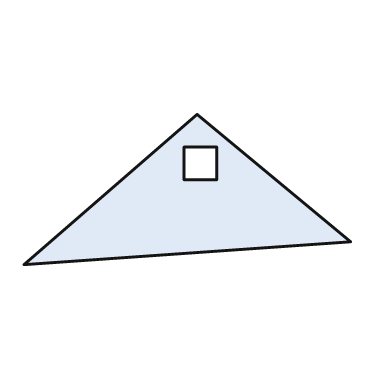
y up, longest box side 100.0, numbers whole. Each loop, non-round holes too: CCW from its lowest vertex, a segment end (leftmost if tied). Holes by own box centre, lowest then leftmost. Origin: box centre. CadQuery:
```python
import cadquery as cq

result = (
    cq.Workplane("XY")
    .moveTo(-50.0, -23.0)
    .lineTo(50.0, -16.0)
    .lineTo(3.0, 23.0)
    .close()
    .moveTo(-1.0, 3.0)
    .lineTo(9.0, 3.0)
    .lineTo(9.0, 13.0)
    .lineTo(-1.0, 13.0)
    .close()
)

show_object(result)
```